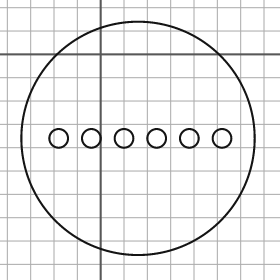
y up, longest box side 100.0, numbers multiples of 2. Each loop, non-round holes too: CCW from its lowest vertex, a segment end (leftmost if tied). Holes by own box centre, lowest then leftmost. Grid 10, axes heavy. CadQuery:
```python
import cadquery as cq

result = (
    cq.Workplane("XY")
    .moveTo(16.0, -36.0)
    .circle(50.0)
    .moveTo(-18.0, -36.0)
    .circle(4.0)
    .moveTo(-4.0, -36.0)
    .circle(4.0)
    .moveTo(10.0, -36.0)
    .circle(4.0)
    .moveTo(24.0, -36.0)
    .circle(4.0)
    .moveTo(38.0, -36.0)
    .circle(4.0)
    .moveTo(52.0, -36.0)
    .circle(4.0)
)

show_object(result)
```